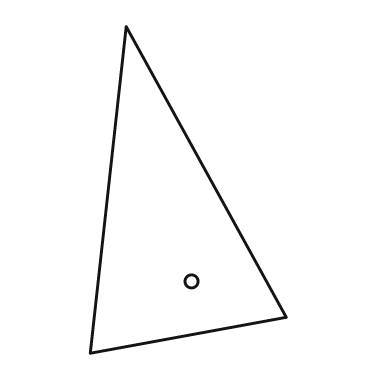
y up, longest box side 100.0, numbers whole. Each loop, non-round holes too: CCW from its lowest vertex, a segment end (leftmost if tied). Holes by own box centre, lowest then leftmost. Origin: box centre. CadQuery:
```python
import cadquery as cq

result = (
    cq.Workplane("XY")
    .moveTo(-30.0, -50.0)
    .lineTo(30.0, -39.0)
    .lineTo(-19.0, 50.0)
    .close()
    .moveTo(1.0, -28.0)
    .circle(2.0)
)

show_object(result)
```